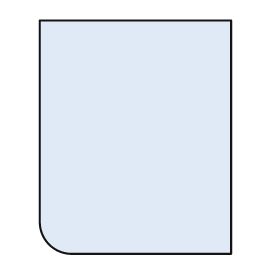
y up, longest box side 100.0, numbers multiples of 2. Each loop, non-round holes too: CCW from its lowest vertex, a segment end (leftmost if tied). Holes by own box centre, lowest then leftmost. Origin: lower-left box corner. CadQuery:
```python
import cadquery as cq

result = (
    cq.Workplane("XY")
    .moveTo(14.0, 0.0)
    .lineTo(82.0, 0.0)
    .lineTo(82.0, 100.0)
    .lineTo(0.0, 100.0)
    .lineTo(0.0, 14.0)
    .threePointArc((4.0, 4.0), (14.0, 0.0))
    .close()
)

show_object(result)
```